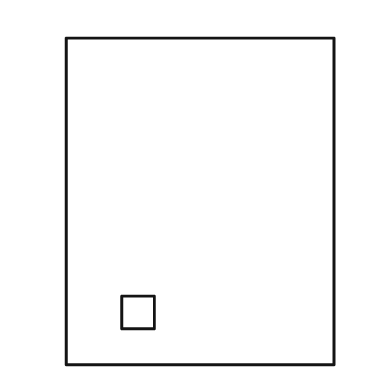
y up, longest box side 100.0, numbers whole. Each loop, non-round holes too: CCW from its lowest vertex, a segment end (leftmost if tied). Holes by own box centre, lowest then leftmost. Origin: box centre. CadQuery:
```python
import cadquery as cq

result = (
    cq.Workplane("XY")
    .moveTo(-41.0, -50.0)
    .lineTo(41.0, -50.0)
    .lineTo(41.0, 50.0)
    .lineTo(-41.0, 50.0)
    .close()
    .moveTo(-24.0, -39.0)
    .lineTo(-14.0, -39.0)
    .lineTo(-14.0, -29.0)
    .lineTo(-24.0, -29.0)
    .close()
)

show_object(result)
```